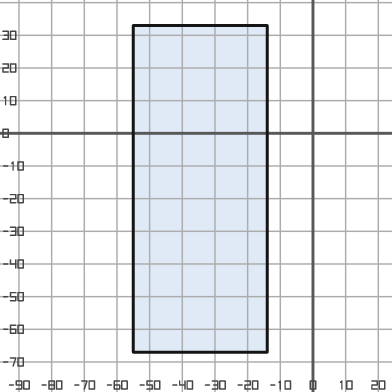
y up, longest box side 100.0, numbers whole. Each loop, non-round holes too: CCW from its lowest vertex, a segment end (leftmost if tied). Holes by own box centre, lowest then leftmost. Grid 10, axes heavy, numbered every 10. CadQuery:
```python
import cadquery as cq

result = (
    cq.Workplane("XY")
    .moveTo(-55.0, -67.0)
    .lineTo(-14.0, -67.0)
    .lineTo(-14.0, 33.0)
    .lineTo(-55.0, 33.0)
    .close()
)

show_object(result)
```